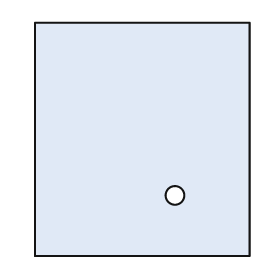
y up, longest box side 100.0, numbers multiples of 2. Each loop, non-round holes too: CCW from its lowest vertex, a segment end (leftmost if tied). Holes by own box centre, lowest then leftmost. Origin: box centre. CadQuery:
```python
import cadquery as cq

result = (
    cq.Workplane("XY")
    .moveTo(-46.0, -50.0)
    .lineTo(46.0, -50.0)
    .lineTo(46.0, 50.0)
    .lineTo(-46.0, 50.0)
    .close()
    .moveTo(14.0, -24.0)
    .circle(4.0)
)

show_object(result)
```